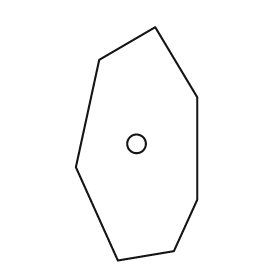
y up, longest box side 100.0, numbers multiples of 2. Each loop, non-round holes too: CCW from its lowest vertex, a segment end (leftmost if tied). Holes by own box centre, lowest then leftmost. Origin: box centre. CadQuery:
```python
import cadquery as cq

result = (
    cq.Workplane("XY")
    .moveTo(-8.0, -50.0)
    .lineTo(16.0, -46.0)
    .lineTo(26.0, -24.0)
    .lineTo(26.0, 20.0)
    .lineTo(8.0, 50.0)
    .lineTo(-16.0, 36.0)
    .lineTo(-26.0, -10.0)
    .close()
    .moveTo(0.0, 0.0)
    .circle(4.0)
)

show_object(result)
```